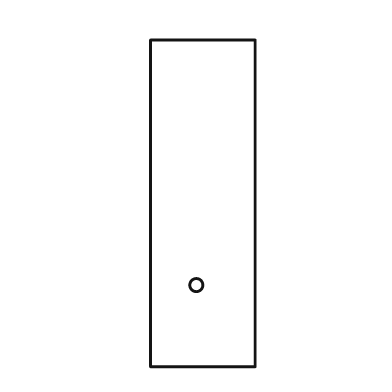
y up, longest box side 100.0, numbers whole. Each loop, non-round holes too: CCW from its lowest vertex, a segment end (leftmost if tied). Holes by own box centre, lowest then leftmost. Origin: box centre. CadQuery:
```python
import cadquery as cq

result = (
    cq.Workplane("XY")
    .moveTo(-16.0, -50.0)
    .lineTo(16.0, -50.0)
    .lineTo(16.0, 50.0)
    .lineTo(-16.0, 50.0)
    .close()
    .moveTo(-2.0, -25.0)
    .circle(2.0)
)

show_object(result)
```